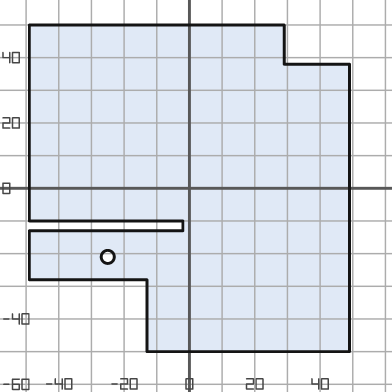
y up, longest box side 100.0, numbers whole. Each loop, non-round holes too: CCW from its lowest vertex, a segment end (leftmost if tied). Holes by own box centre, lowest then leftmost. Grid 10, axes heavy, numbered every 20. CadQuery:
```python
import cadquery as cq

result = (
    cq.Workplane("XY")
    .moveTo(-13.0, -50.0)
    .lineTo(49.0, -50.0)
    .lineTo(49.0, 38.0)
    .lineTo(29.0, 38.0)
    .lineTo(29.0, 50.0)
    .lineTo(-49.0, 50.0)
    .lineTo(-49.0, -10.0)
    .lineTo(-2.0, -10.0)
    .lineTo(-2.0, -13.0)
    .lineTo(-49.0, -13.0)
    .lineTo(-49.0, -28.0)
    .lineTo(-13.0, -28.0)
    .close()
    .moveTo(-25.0, -21.0)
    .circle(2.0)
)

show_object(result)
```